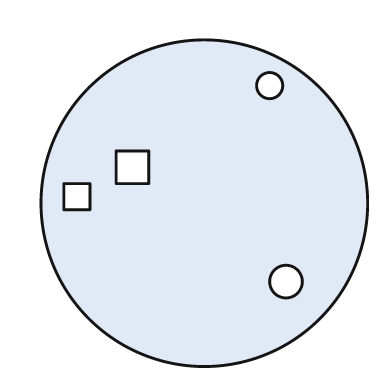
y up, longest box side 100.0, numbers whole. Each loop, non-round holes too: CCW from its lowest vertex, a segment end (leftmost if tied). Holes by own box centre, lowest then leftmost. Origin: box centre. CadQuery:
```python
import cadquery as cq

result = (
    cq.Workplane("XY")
    .moveTo(0.0, 0.0)
    .circle(50.0)
    .moveTo(25.0, -24.0)
    .circle(5.0)
    .moveTo(-43.0, -2.0)
    .lineTo(-35.0, -2.0)
    .lineTo(-35.0, 6.0)
    .lineTo(-43.0, 6.0)
    .close()
    .moveTo(-27.0, 6.0)
    .lineTo(-17.0, 6.0)
    .lineTo(-17.0, 16.0)
    .lineTo(-27.0, 16.0)
    .close()
    .moveTo(20.0, 36.0)
    .circle(4.0)
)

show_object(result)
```